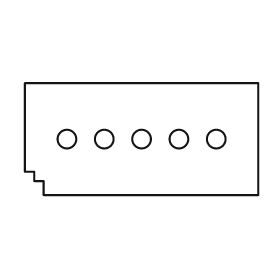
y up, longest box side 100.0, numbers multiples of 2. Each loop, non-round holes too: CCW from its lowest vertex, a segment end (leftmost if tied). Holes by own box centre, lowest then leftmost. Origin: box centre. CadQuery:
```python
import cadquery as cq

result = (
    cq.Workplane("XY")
    .moveTo(-42.0, -24.0)
    .lineTo(50.0, -24.0)
    .lineTo(50.0, 24.0)
    .lineTo(-50.0, 24.0)
    .lineTo(-50.0, -14.0)
    .lineTo(-46.0, -14.0)
    .lineTo(-46.0, -18.0)
    .lineTo(-42.0, -18.0)
    .close()
    .moveTo(-32.0, 0.0)
    .circle(4.0)
    .moveTo(-16.0, 0.0)
    .circle(4.0)
    .moveTo(0.0, 0.0)
    .circle(4.0)
    .moveTo(16.0, 0.0)
    .circle(4.0)
    .moveTo(32.0, 0.0)
    .circle(4.0)
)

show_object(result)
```